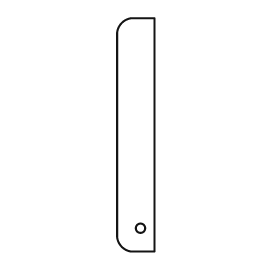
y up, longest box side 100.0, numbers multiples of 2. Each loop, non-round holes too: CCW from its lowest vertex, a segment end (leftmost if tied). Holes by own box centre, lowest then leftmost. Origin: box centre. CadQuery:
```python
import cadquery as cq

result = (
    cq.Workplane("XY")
    .moveTo(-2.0, -50.0)
    .lineTo(8.0, -50.0)
    .lineTo(8.0, 50.0)
    .lineTo(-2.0, 50.0)
    .threePointArc((-6.0, 48.0), (-8.0, 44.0))
    .lineTo(-8.0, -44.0)
    .threePointArc((-6.0, -48.0), (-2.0, -50.0))
    .close()
    .moveTo(2.0, -40.0)
    .circle(2.0)
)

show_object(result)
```